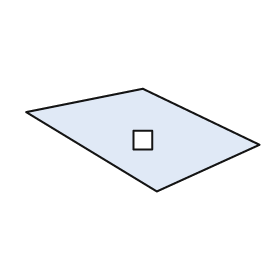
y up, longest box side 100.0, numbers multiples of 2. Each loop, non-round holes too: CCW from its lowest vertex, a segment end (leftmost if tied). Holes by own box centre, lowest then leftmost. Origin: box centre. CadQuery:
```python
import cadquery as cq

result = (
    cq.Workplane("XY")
    .moveTo(6.0, -22.0)
    .lineTo(50.0, -2.0)
    .lineTo(0.0, 22.0)
    .lineTo(-50.0, 12.0)
    .close()
    .moveTo(-4.0, -4.0)
    .lineTo(4.0, -4.0)
    .lineTo(4.0, 4.0)
    .lineTo(-4.0, 4.0)
    .close()
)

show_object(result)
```